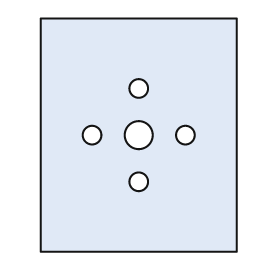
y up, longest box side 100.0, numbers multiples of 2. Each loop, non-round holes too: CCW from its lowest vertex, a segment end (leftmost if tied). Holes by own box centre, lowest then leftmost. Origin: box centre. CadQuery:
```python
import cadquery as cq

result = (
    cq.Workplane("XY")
    .moveTo(-42.0, -50.0)
    .lineTo(42.0, -50.0)
    .lineTo(42.0, 50.0)
    .lineTo(-42.0, 50.0)
    .close()
    .moveTo(0.0, -20.0)
    .circle(4.0)
    .moveTo(-20.0, 0.0)
    .circle(4.0)
    .moveTo(0.0, 0.0)
    .circle(6.0)
    .moveTo(20.0, 0.0)
    .circle(4.0)
    .moveTo(0.0, 20.0)
    .circle(4.0)
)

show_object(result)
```